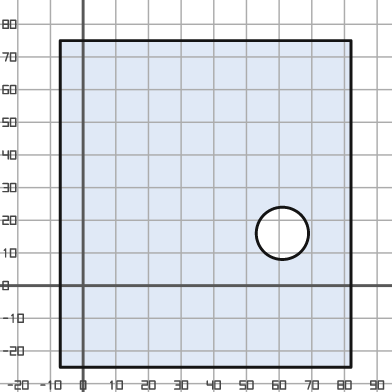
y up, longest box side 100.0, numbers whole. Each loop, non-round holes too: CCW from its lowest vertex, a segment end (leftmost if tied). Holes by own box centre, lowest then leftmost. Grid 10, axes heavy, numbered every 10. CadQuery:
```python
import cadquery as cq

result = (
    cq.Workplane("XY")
    .moveTo(-7.0, -25.0)
    .lineTo(82.0, -25.0)
    .lineTo(82.0, 75.0)
    .lineTo(-7.0, 75.0)
    .close()
    .moveTo(61.0, 16.0)
    .circle(8.0)
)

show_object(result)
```